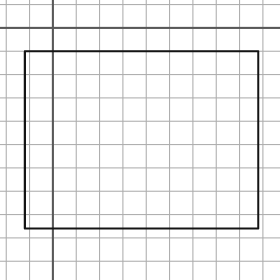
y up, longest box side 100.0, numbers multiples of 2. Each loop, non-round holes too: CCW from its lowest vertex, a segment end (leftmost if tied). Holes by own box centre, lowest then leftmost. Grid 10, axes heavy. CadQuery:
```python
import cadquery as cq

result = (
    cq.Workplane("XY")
    .moveTo(-12.0, -86.0)
    .lineTo(88.0, -86.0)
    .lineTo(88.0, -10.0)
    .lineTo(-12.0, -10.0)
    .close()
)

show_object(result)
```